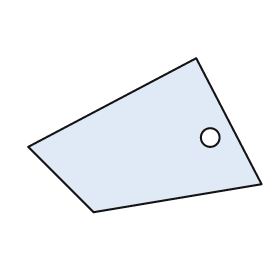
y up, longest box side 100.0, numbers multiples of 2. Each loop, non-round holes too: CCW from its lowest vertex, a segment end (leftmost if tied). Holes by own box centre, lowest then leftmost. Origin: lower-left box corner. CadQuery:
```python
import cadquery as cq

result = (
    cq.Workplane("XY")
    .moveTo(28.0, 0.0)
    .lineTo(100.0, 12.0)
    .lineTo(72.0, 66.0)
    .lineTo(0.0, 28.0)
    .close()
    .moveTo(78.0, 32.0)
    .circle(4.0)
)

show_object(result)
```